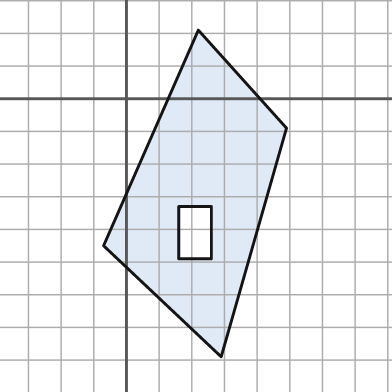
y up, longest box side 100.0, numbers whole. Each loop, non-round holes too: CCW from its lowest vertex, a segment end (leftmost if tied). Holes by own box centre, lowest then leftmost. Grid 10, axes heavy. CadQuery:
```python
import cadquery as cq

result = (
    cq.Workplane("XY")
    .moveTo(29.0, -79.0)
    .lineTo(49.0, -9.0)
    .lineTo(22.0, 21.0)
    .lineTo(-7.0, -45.0)
    .close()
    .moveTo(16.0, -49.0)
    .lineTo(26.0, -49.0)
    .lineTo(26.0, -33.0)
    .lineTo(16.0, -33.0)
    .close()
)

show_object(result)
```